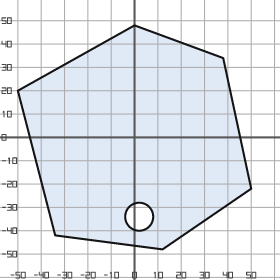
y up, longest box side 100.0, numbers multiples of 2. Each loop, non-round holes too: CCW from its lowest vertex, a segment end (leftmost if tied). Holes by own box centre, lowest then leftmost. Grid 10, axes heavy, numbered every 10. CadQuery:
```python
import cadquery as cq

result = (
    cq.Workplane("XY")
    .moveTo(12.0, -48.0)
    .lineTo(50.0, -22.0)
    .lineTo(38.0, 34.0)
    .lineTo(0.0, 48.0)
    .lineTo(-50.0, 20.0)
    .lineTo(-34.0, -42.0)
    .close()
    .moveTo(2.0, -34.0)
    .circle(6.0)
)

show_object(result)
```